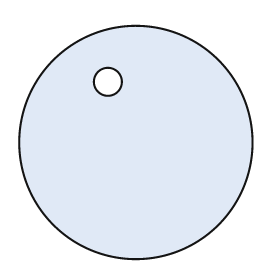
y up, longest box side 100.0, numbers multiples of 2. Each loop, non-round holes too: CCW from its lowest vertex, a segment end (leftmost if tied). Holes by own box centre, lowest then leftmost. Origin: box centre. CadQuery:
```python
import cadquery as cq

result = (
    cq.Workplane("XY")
    .moveTo(0.0, 0.0)
    .circle(50.0)
    .moveTo(-12.0, 26.0)
    .circle(6.0)
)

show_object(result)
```